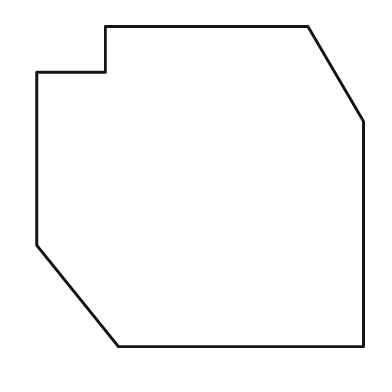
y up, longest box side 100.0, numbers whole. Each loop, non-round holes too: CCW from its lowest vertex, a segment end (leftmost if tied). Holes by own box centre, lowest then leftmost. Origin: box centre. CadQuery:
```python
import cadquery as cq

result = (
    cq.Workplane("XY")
    .moveTo(-25.0, -49.0)
    .lineTo(50.0, -49.0)
    .lineTo(50.0, 20.0)
    .lineTo(33.0, 49.0)
    .lineTo(-29.0, 49.0)
    .lineTo(-29.0, 35.0)
    .lineTo(-50.0, 35.0)
    .lineTo(-50.0, -18.0)
    .close()
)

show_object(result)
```